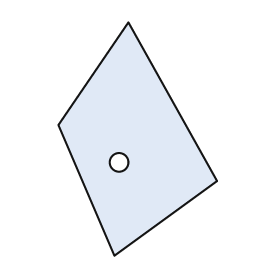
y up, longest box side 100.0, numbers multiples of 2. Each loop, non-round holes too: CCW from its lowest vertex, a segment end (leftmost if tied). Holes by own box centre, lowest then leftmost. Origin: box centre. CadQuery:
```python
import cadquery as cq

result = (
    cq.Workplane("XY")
    .moveTo(-10.0, -50.0)
    .lineTo(34.0, -18.0)
    .lineTo(-4.0, 50.0)
    .lineTo(-34.0, 6.0)
    .close()
    .moveTo(-8.0, -10.0)
    .circle(4.0)
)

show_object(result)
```